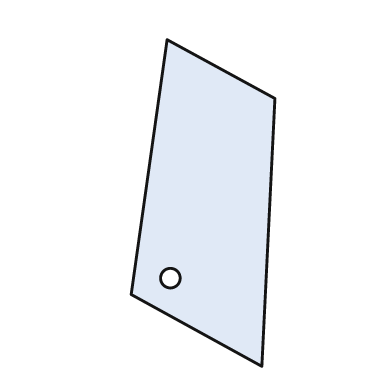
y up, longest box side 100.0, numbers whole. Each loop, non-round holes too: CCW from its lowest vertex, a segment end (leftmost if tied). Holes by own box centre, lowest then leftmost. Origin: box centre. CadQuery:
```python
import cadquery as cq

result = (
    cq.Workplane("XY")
    .moveTo(18.0, -50.0)
    .lineTo(22.0, 32.0)
    .lineTo(-11.0, 50.0)
    .lineTo(-22.0, -28.0)
    .close()
    .moveTo(-10.0, -23.0)
    .circle(3.0)
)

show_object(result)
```